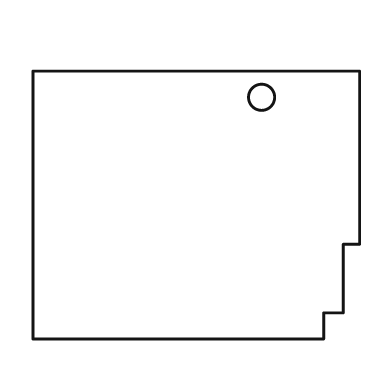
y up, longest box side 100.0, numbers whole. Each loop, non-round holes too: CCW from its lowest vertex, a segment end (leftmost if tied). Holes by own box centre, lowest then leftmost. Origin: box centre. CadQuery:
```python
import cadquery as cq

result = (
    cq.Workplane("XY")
    .moveTo(-50.0, -41.0)
    .lineTo(39.0, -41.0)
    .lineTo(39.0, -33.0)
    .lineTo(45.0, -33.0)
    .lineTo(45.0, -12.0)
    .lineTo(50.0, -12.0)
    .lineTo(50.0, 41.0)
    .lineTo(-50.0, 41.0)
    .close()
    .moveTo(20.0, 33.0)
    .circle(4.0)
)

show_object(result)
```